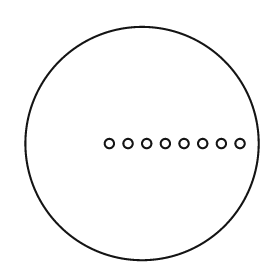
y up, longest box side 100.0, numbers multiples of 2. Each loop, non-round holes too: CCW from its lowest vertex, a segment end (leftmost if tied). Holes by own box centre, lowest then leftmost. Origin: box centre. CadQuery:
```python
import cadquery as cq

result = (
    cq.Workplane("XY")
    .moveTo(0.0, 0.0)
    .circle(50.0)
    .moveTo(-14.0, 0.0)
    .circle(2.0)
    .moveTo(-6.0, 0.0)
    .circle(2.0)
    .moveTo(2.0, 0.0)
    .circle(2.0)
    .moveTo(10.0, 0.0)
    .circle(2.0)
    .moveTo(18.0, 0.0)
    .circle(2.0)
    .moveTo(26.0, 0.0)
    .circle(2.0)
    .moveTo(34.0, 0.0)
    .circle(2.0)
    .moveTo(42.0, 0.0)
    .circle(2.0)
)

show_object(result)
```